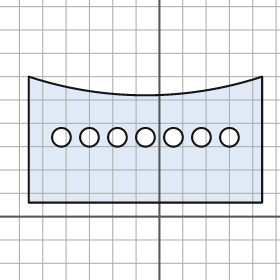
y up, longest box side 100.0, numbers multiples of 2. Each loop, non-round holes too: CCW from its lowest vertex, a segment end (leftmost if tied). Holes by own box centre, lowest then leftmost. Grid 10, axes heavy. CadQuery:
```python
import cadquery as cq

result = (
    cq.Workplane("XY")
    .moveTo(-56.0, 6.0)
    .lineTo(44.0, 6.0)
    .lineTo(44.0, 60.0)
    .threePointArc((-6.0, 52.0), (-56.0, 60.0))
    .close()
    .moveTo(-42.0, 34.0)
    .circle(4.0)
    .moveTo(-30.0, 34.0)
    .circle(4.0)
    .moveTo(-18.0, 34.0)
    .circle(4.0)
    .moveTo(-6.0, 34.0)
    .circle(4.0)
    .moveTo(6.0, 34.0)
    .circle(4.0)
    .moveTo(18.0, 34.0)
    .circle(4.0)
    .moveTo(30.0, 34.0)
    .circle(4.0)
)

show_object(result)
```